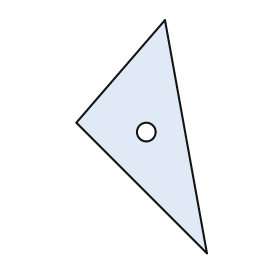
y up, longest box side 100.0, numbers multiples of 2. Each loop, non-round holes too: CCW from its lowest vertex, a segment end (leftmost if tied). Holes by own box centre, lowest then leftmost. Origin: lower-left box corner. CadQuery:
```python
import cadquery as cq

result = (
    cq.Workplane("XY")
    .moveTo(56.0, 0.0)
    .lineTo(38.0, 100.0)
    .lineTo(0.0, 56.0)
    .close()
    .moveTo(30.0, 52.0)
    .circle(4.0)
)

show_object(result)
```